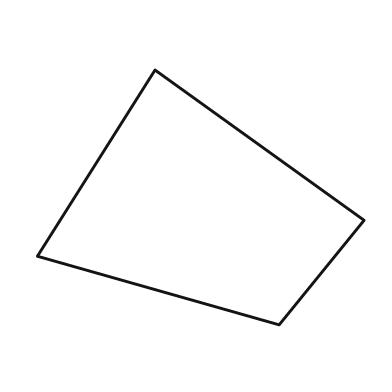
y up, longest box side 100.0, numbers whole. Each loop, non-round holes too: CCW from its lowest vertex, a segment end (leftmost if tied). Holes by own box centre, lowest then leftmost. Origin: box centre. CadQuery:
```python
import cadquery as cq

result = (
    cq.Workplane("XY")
    .moveTo(24.0, -39.0)
    .lineTo(50.0, -7.0)
    .lineTo(-14.0, 39.0)
    .lineTo(-50.0, -18.0)
    .close()
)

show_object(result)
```